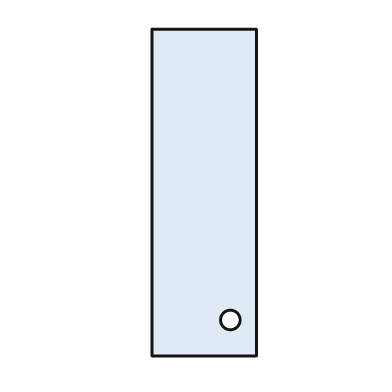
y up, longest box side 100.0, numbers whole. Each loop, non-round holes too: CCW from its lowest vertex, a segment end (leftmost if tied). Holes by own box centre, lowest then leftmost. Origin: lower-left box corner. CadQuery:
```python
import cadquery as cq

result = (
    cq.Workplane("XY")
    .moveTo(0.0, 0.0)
    .lineTo(32.0, 0.0)
    .lineTo(32.0, 100.0)
    .lineTo(0.0, 100.0)
    .close()
    .moveTo(24.0, 11.0)
    .circle(3.0)
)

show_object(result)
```